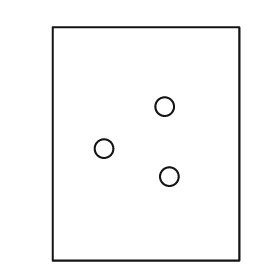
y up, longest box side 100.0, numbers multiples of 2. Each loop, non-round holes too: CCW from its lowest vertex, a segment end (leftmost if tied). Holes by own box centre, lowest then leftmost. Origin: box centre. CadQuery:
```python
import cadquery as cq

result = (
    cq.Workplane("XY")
    .moveTo(-40.0, -50.0)
    .lineTo(40.0, -50.0)
    .lineTo(40.0, 50.0)
    .lineTo(-40.0, 50.0)
    .close()
    .moveTo(10.0, -14.0)
    .circle(4.0)
    .moveTo(-18.0, -2.0)
    .circle(4.0)
    .moveTo(8.0, 16.0)
    .circle(4.0)
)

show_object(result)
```